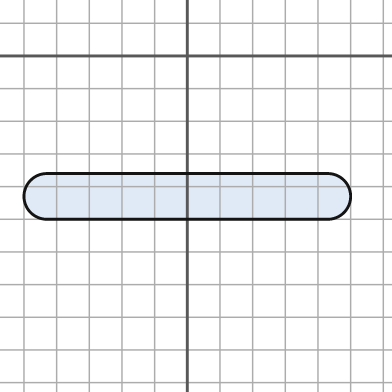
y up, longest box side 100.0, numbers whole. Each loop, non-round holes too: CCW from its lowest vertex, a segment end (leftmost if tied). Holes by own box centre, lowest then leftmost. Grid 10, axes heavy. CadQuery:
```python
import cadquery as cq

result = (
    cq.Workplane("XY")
    .moveTo(-43.0, -50.0)
    .lineTo(43.0, -50.0)
    .threePointArc((50.0, -43.0), (43.0, -36.0))
    .lineTo(-43.0, -36.0)
    .threePointArc((-50.0, -43.0), (-43.0, -50.0))
    .close()
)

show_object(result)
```